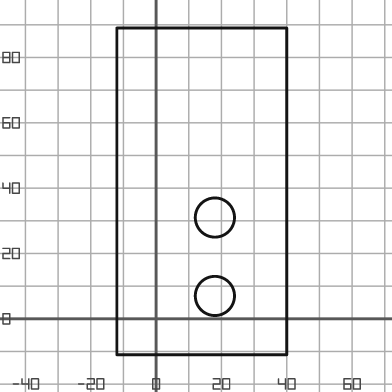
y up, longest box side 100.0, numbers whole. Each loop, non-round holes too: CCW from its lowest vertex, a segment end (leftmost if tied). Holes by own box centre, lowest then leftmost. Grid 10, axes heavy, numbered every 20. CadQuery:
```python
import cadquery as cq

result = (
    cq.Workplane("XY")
    .moveTo(-12.0, -11.0)
    .lineTo(40.0, -11.0)
    .lineTo(40.0, 89.0)
    .lineTo(-12.0, 89.0)
    .close()
    .moveTo(18.0, 7.0)
    .circle(6.0)
    .moveTo(18.0, 31.0)
    .circle(6.0)
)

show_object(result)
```